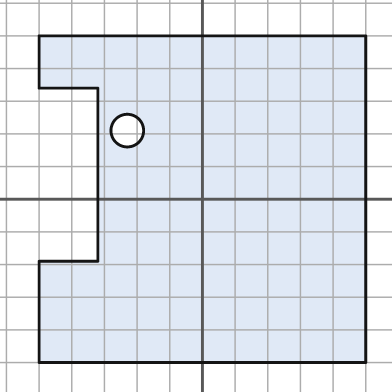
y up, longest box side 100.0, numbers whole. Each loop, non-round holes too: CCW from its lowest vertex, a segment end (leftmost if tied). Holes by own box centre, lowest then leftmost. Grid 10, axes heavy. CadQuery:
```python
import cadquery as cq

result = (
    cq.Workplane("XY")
    .moveTo(-50.0, -50.0)
    .lineTo(50.0, -50.0)
    .lineTo(50.0, 50.0)
    .lineTo(-50.0, 50.0)
    .lineTo(-50.0, 34.0)
    .lineTo(-32.0, 34.0)
    .lineTo(-32.0, -19.0)
    .lineTo(-50.0, -19.0)
    .close()
    .moveTo(-23.0, 21.0)
    .circle(5.0)
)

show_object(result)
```